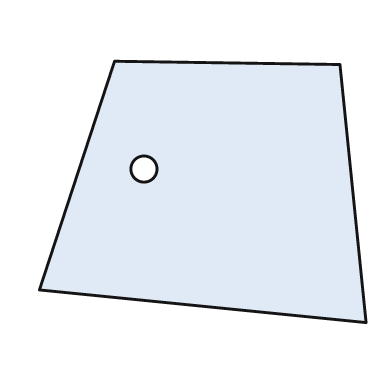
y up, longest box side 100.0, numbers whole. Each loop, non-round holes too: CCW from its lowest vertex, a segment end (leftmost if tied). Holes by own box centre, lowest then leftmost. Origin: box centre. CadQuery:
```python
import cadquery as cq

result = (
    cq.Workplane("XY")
    .moveTo(50.0, -40.0)
    .lineTo(42.0, 39.0)
    .lineTo(-27.0, 40.0)
    .lineTo(-50.0, -30.0)
    .close()
    .moveTo(-18.0, 7.0)
    .circle(4.0)
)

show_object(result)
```